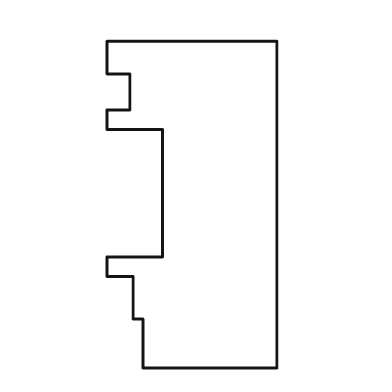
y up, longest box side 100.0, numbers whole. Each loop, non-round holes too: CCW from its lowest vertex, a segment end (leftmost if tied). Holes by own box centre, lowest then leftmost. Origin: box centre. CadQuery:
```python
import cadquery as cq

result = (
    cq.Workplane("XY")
    .moveTo(-15.0, -50.0)
    .lineTo(26.0, -50.0)
    .lineTo(26.0, 50.0)
    .lineTo(-26.0, 50.0)
    .lineTo(-26.0, 40.0)
    .lineTo(-19.0, 40.0)
    .lineTo(-19.0, 29.0)
    .lineTo(-26.0, 29.0)
    .lineTo(-26.0, 23.0)
    .lineTo(-9.0, 23.0)
    .lineTo(-9.0, -16.0)
    .lineTo(-26.0, -16.0)
    .lineTo(-26.0, -22.0)
    .lineTo(-18.0, -22.0)
    .lineTo(-18.0, -35.0)
    .lineTo(-15.0, -35.0)
    .close()
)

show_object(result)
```